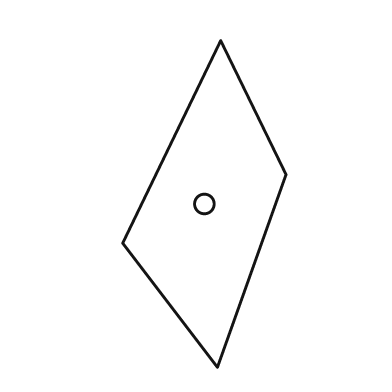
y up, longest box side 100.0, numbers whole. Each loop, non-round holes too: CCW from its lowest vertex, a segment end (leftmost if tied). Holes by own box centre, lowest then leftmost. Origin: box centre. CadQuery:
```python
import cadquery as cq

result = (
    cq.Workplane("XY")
    .moveTo(4.0, -50.0)
    .lineTo(25.0, 9.0)
    .lineTo(5.0, 50.0)
    .lineTo(-25.0, -12.0)
    .close()
    .moveTo(0.0, 0.0)
    .circle(3.0)
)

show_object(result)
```